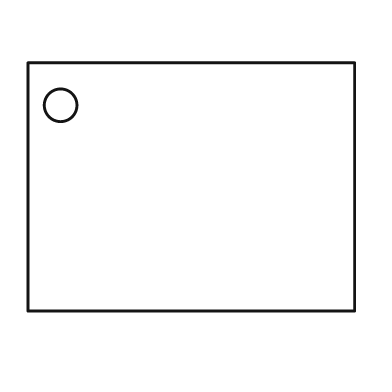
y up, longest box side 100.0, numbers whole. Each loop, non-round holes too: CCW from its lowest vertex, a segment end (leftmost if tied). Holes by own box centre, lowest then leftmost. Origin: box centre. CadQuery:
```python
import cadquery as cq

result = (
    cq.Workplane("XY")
    .moveTo(-50.0, -38.0)
    .lineTo(50.0, -38.0)
    .lineTo(50.0, 38.0)
    .lineTo(-50.0, 38.0)
    .close()
    .moveTo(-40.0, 25.0)
    .circle(5.0)
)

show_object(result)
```